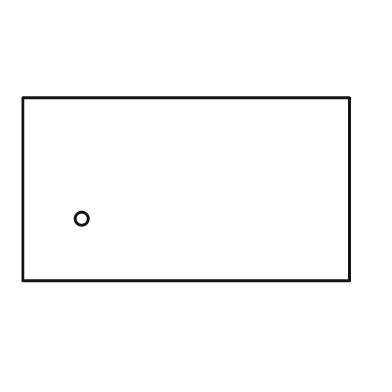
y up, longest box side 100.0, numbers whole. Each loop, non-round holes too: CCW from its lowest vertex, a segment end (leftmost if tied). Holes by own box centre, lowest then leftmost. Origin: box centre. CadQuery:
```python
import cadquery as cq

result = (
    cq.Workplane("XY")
    .moveTo(-50.0, -28.0)
    .lineTo(50.0, -28.0)
    .lineTo(50.0, 28.0)
    .lineTo(-50.0, 28.0)
    .close()
    .moveTo(-32.0, -9.0)
    .circle(2.0)
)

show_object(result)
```